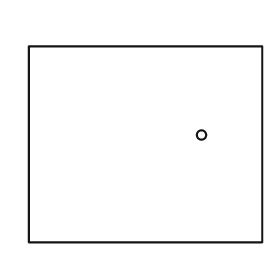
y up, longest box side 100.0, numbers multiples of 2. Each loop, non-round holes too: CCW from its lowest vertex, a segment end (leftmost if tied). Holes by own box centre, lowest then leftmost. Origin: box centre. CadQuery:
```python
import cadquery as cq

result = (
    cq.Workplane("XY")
    .moveTo(-50.0, -42.0)
    .lineTo(50.0, -42.0)
    .lineTo(50.0, 42.0)
    .lineTo(-50.0, 42.0)
    .close()
    .moveTo(24.0, 4.0)
    .circle(2.0)
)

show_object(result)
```